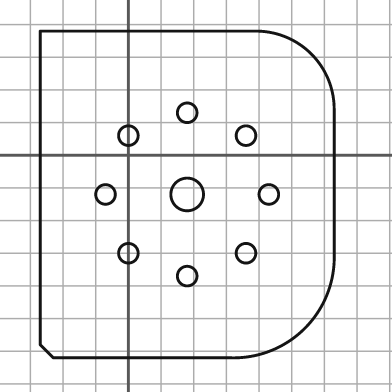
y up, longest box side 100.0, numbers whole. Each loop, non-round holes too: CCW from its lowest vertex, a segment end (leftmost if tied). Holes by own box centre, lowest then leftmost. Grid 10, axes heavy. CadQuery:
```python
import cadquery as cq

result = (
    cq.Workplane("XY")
    .moveTo(-23.0, -62.0)
    .lineTo(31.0, -62.0)
    .threePointArc((54.0, -53.0), (63.0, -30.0))
    .lineTo(63.0, 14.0)
    .threePointArc((56.0, 31.0), (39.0, 38.0))
    .lineTo(-27.0, 38.0)
    .lineTo(-27.0, -58.0)
    .close()
    .moveTo(18.0, -37.0)
    .circle(3.0)
    .moveTo(0.0, -30.0)
    .circle(3.0)
    .moveTo(36.0, -30.0)
    .circle(3.0)
    .moveTo(-7.0, -12.0)
    .circle(3.0)
    .moveTo(18.0, -12.0)
    .circle(5.0)
    .moveTo(43.0, -12.0)
    .circle(3.0)
    .moveTo(0.0, 6.0)
    .circle(3.0)
    .moveTo(36.0, 6.0)
    .circle(3.0)
    .moveTo(18.0, 13.0)
    .circle(3.0)
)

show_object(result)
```